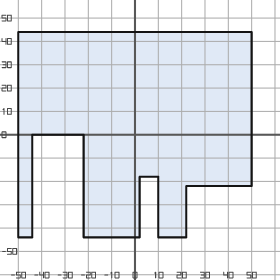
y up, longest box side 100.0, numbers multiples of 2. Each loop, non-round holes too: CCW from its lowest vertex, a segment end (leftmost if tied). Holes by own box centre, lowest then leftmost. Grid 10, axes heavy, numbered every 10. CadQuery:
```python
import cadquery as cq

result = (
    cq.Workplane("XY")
    .moveTo(-50.0, -44.0)
    .lineTo(-44.0, -44.0)
    .lineTo(-44.0, 0.0)
    .lineTo(-22.0, 0.0)
    .lineTo(-22.0, -44.0)
    .lineTo(2.0, -44.0)
    .lineTo(2.0, -18.0)
    .lineTo(10.0, -18.0)
    .lineTo(10.0, -44.0)
    .lineTo(22.0, -44.0)
    .lineTo(22.0, -22.0)
    .lineTo(50.0, -22.0)
    .lineTo(50.0, 44.0)
    .lineTo(-50.0, 44.0)
    .close()
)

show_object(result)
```